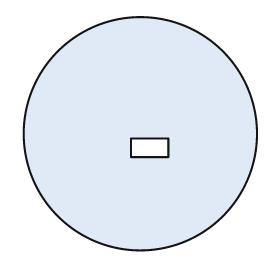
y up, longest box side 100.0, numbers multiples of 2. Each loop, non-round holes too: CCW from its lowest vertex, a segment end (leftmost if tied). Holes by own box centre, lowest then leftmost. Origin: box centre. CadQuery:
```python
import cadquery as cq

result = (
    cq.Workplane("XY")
    .moveTo(0.0, 0.0)
    .circle(50.0)
    .moveTo(-4.0, -10.0)
    .lineTo(12.0, -10.0)
    .lineTo(12.0, -2.0)
    .lineTo(-4.0, -2.0)
    .close()
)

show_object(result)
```